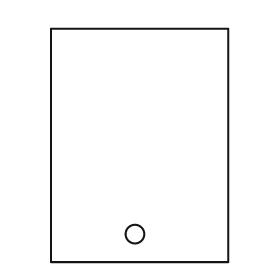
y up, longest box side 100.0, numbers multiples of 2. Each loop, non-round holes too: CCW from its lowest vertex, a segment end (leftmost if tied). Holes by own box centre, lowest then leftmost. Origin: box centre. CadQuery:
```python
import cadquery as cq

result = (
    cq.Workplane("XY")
    .moveTo(-38.0, -50.0)
    .lineTo(38.0, -50.0)
    .lineTo(38.0, 50.0)
    .lineTo(-38.0, 50.0)
    .close()
    .moveTo(-2.0, -38.0)
    .circle(4.0)
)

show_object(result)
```